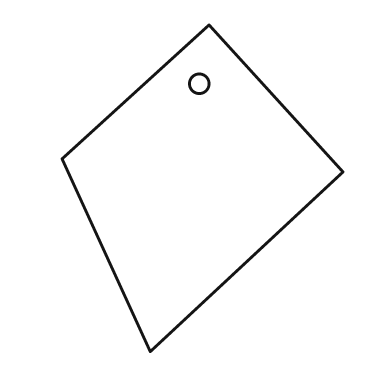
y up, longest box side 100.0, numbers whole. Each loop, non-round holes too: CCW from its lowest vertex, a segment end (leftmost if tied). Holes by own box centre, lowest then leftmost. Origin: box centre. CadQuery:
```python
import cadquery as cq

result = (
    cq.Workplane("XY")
    .moveTo(-16.0, -50.0)
    .lineTo(43.0, 5.0)
    .lineTo(2.0, 50.0)
    .lineTo(-43.0, 9.0)
    .close()
    .moveTo(-1.0, 32.0)
    .circle(3.0)
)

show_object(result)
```